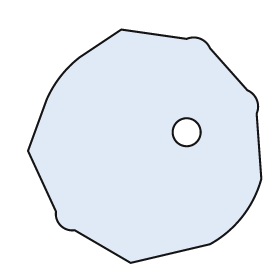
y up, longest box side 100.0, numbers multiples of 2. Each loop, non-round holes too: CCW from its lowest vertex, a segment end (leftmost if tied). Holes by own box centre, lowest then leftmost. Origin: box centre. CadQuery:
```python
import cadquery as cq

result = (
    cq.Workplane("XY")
    .moveTo(-6.0, -50.0)
    .lineTo(28.0, -42.0)
    .threePointArc((42.0, -30.0), (50.0, -14.0))
    .lineTo(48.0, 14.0)
    .threePointArc((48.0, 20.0), (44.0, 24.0))
    .lineTo(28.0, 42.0)
    .threePointArc((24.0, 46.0), (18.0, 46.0))
    .lineTo(-10.0, 50.0)
    .lineTo(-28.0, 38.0)
    .threePointArc((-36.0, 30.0), (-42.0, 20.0))
    .lineTo(-50.0, -2.0)
    .lineTo(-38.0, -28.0)
    .threePointArc((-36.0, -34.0), (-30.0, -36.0))
    .close()
    .moveTo(18.0, 6.0)
    .circle(6.0)
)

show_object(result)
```